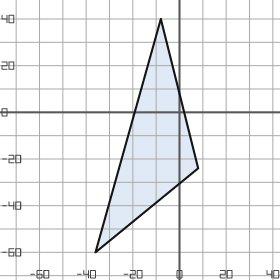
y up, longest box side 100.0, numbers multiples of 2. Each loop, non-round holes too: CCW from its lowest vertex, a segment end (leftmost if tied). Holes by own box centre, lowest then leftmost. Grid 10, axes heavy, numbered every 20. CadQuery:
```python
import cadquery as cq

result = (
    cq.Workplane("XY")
    .moveTo(-36.0, -60.0)
    .lineTo(8.0, -24.0)
    .lineTo(-8.0, 40.0)
    .close()
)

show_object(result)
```